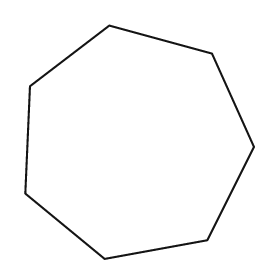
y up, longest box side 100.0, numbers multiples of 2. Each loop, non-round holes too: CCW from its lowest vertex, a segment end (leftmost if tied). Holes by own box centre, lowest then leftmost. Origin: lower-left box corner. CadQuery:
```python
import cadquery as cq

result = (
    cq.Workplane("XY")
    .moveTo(34.0, 0.0)
    .lineTo(78.0, 8.0)
    .lineTo(98.0, 48.0)
    .lineTo(80.0, 88.0)
    .lineTo(36.0, 100.0)
    .lineTo(2.0, 74.0)
    .lineTo(0.0, 28.0)
    .close()
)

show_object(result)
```